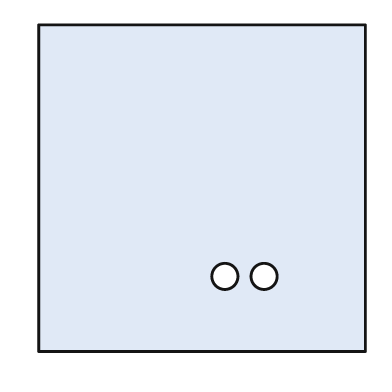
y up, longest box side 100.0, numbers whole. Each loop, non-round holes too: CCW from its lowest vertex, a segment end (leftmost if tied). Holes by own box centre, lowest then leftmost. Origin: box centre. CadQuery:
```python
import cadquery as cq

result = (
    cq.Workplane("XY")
    .moveTo(-50.0, -50.0)
    .lineTo(50.0, -50.0)
    .lineTo(50.0, 50.0)
    .lineTo(-50.0, 50.0)
    .close()
    .moveTo(7.0, -27.0)
    .circle(4.0)
    .moveTo(19.0, -27.0)
    .circle(4.0)
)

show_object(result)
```